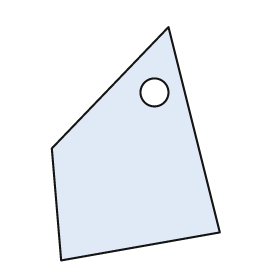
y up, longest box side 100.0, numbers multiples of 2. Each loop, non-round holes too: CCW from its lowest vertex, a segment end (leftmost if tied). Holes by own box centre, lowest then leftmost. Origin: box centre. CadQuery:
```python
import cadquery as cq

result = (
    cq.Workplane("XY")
    .moveTo(-32.0, -50.0)
    .lineTo(36.0, -38.0)
    .lineTo(14.0, 50.0)
    .lineTo(-36.0, -2.0)
    .close()
    .moveTo(8.0, 22.0)
    .circle(6.0)
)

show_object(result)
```